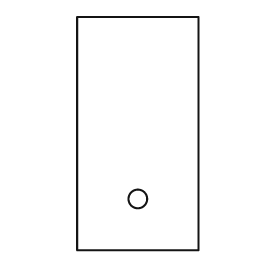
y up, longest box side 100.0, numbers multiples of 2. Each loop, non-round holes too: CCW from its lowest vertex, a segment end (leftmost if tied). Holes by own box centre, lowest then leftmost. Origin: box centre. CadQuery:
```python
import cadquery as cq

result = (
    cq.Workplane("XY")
    .moveTo(-26.0, -50.0)
    .lineTo(26.0, -50.0)
    .lineTo(26.0, 50.0)
    .lineTo(-26.0, 50.0)
    .close()
    .moveTo(0.0, -28.0)
    .circle(4.0)
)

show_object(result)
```